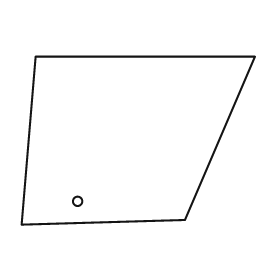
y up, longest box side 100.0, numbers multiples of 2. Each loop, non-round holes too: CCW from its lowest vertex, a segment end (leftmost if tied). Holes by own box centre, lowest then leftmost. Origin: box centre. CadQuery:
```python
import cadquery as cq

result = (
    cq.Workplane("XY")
    .moveTo(-50.0, -36.0)
    .lineTo(20.0, -34.0)
    .lineTo(50.0, 36.0)
    .lineTo(-44.0, 36.0)
    .close()
    .moveTo(-26.0, -26.0)
    .circle(2.0)
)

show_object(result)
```